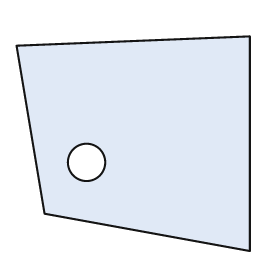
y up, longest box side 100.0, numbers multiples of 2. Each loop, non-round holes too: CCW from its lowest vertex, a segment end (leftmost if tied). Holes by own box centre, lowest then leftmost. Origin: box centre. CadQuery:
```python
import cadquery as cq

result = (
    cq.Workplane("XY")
    .moveTo(50.0, -46.0)
    .lineTo(50.0, 46.0)
    .lineTo(-50.0, 42.0)
    .lineTo(-38.0, -30.0)
    .close()
    .moveTo(-20.0, -8.0)
    .circle(8.0)
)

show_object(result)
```